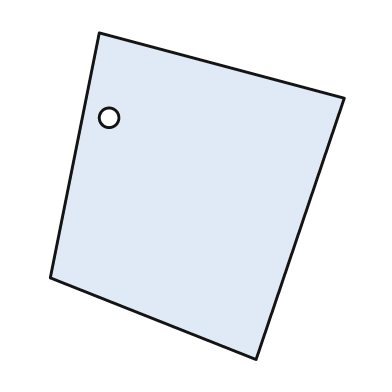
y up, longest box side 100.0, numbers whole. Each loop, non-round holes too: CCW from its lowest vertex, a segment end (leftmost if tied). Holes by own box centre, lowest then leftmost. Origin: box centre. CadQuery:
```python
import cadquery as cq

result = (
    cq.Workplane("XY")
    .moveTo(18.0, -50.0)
    .lineTo(45.0, 30.0)
    .lineTo(-30.0, 50.0)
    .lineTo(-45.0, -25.0)
    .close()
    .moveTo(-27.0, 24.0)
    .circle(3.0)
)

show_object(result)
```